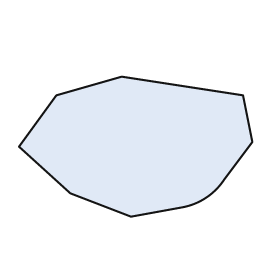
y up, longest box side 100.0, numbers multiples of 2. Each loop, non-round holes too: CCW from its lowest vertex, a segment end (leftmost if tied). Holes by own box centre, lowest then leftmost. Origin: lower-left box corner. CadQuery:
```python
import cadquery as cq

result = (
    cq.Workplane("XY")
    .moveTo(48.0, 0.0)
    .lineTo(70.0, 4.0)
    .threePointArc((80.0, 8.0), (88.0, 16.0))
    .lineTo(100.0, 32.0)
    .lineTo(96.0, 52.0)
    .lineTo(44.0, 60.0)
    .lineTo(16.0, 52.0)
    .lineTo(0.0, 30.0)
    .lineTo(22.0, 10.0)
    .close()
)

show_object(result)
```